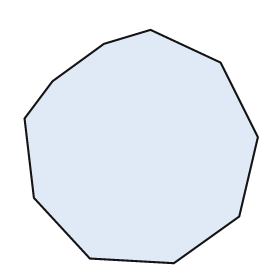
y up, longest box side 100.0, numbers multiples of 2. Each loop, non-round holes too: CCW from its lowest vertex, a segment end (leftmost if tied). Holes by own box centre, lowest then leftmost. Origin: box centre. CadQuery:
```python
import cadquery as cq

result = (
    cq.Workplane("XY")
    .moveTo(14.0, -50.0)
    .lineTo(42.0, -30.0)
    .lineTo(50.0, 4.0)
    .lineTo(34.0, 36.0)
    .lineTo(4.0, 50.0)
    .lineTo(-16.0, 44.0)
    .lineTo(-38.0, 28.0)
    .lineTo(-50.0, 12.0)
    .lineTo(-46.0, -22.0)
    .lineTo(-22.0, -48.0)
    .close()
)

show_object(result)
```